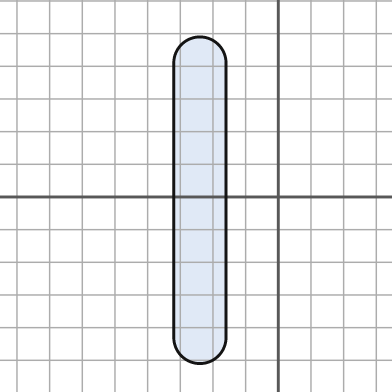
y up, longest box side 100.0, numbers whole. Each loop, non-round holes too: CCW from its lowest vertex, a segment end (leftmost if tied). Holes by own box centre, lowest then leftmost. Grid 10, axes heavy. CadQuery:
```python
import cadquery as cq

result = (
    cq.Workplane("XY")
    .moveTo(-32.0, -43.0)
    .threePointArc((-24.0, -51.0), (-16.0, -43.0))
    .lineTo(-16.0, 41.0)
    .threePointArc((-24.0, 49.0), (-32.0, 41.0))
    .close()
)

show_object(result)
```